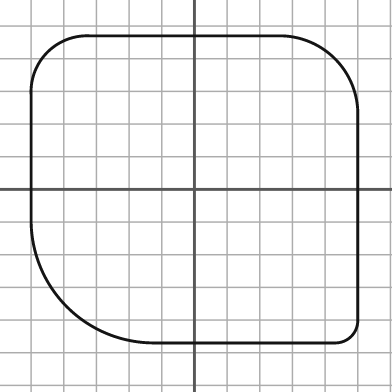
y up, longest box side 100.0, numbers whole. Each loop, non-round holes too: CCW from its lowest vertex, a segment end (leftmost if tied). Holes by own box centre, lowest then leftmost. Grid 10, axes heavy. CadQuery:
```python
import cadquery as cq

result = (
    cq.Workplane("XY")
    .moveTo(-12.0, -47.0)
    .lineTo(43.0, -47.0)
    .threePointArc((48.0, -45.0), (50.0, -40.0))
    .lineTo(50.0, 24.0)
    .threePointArc((43.0, 40.0), (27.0, 47.0))
    .lineTo(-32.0, 47.0)
    .threePointArc((-45.0, 42.0), (-50.0, 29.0))
    .lineTo(-50.0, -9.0)
    .threePointArc((-39.0, -36.0), (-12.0, -47.0))
    .close()
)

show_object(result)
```